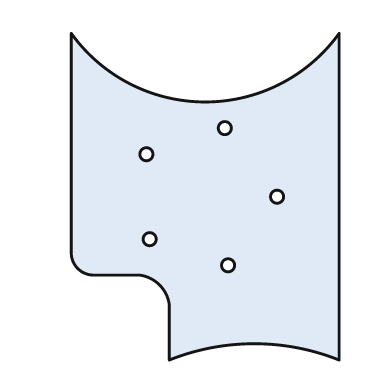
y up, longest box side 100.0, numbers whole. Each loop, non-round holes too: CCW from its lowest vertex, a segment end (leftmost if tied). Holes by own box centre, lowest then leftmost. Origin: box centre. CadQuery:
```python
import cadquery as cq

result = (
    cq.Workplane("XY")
    .moveTo(-11.0, -50.0)
    .threePointArc((15.0, -45.0), (41.0, -50.0))
    .lineTo(41.0, 50.0)
    .threePointArc((0.0, 29.0), (-41.0, 50.0))
    .lineTo(-41.0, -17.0)
    .threePointArc((-39.0, -22.0), (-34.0, -24.0))
    .lineTo(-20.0, -24.0)
    .threePointArc((-14.0, -27.0), (-11.0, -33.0))
    .close()
    .moveTo(7.0, -21.0)
    .circle(2.0)
    .moveTo(-17.0, -13.0)
    .circle(2.0)
    .moveTo(22.0, 0.0)
    .circle(2.0)
    .moveTo(-18.0, 13.0)
    .circle(2.0)
    .moveTo(6.0, 21.0)
    .circle(2.0)
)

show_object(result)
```